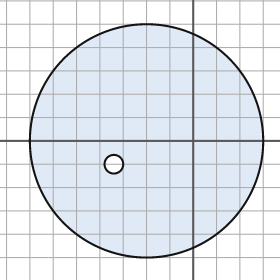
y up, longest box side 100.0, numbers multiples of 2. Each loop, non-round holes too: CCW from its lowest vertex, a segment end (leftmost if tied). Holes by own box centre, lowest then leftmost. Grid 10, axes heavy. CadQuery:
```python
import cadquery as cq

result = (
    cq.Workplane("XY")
    .moveTo(-20.0, 0.0)
    .circle(50.0)
    .moveTo(-34.0, -10.0)
    .circle(4.0)
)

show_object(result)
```